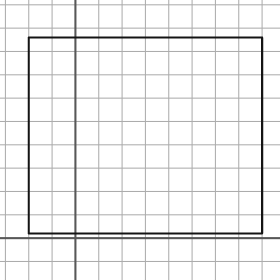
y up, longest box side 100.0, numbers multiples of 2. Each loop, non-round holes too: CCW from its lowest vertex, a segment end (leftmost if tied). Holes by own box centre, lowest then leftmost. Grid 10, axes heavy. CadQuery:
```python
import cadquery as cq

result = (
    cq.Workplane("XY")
    .moveTo(-20.0, 2.0)
    .lineTo(80.0, 2.0)
    .lineTo(80.0, 86.0)
    .lineTo(-20.0, 86.0)
    .close()
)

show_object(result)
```